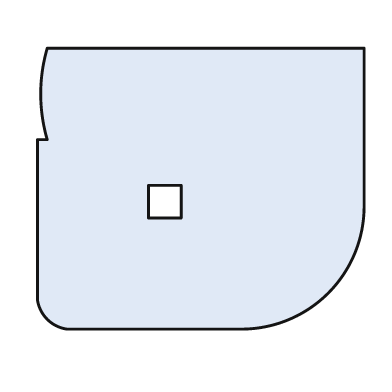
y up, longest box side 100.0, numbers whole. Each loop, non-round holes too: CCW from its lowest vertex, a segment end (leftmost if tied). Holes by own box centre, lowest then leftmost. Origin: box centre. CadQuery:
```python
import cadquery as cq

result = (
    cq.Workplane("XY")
    .moveTo(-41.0, -43.0)
    .lineTo(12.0, -43.0)
    .threePointArc((39.0, -32.0), (50.0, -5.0))
    .lineTo(50.0, 43.0)
    .lineTo(-47.0, 43.0)
    .threePointArc((-49.0, 29.0), (-47.0, 15.0))
    .lineTo(-50.0, 15.0)
    .lineTo(-50.0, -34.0)
    .threePointArc((-47.0, -40.0), (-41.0, -43.0))
    .close()
    .moveTo(-16.0, -9.0)
    .lineTo(-6.0, -9.0)
    .lineTo(-6.0, 1.0)
    .lineTo(-16.0, 1.0)
    .close()
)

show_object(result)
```